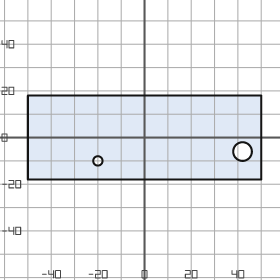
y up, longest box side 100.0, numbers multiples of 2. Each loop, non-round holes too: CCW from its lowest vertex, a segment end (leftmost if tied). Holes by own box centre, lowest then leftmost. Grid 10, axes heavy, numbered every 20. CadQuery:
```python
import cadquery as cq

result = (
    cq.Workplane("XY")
    .moveTo(-50.0, -18.0)
    .lineTo(50.0, -18.0)
    .lineTo(50.0, 18.0)
    .lineTo(-50.0, 18.0)
    .close()
    .moveTo(-20.0, -10.0)
    .circle(2.0)
    .moveTo(42.0, -6.0)
    .circle(4.0)
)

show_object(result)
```